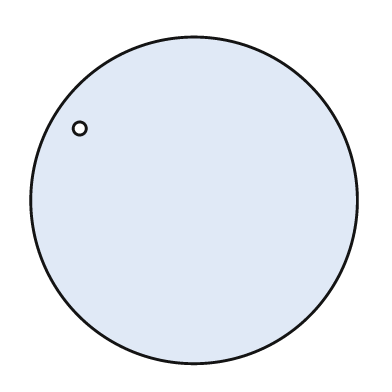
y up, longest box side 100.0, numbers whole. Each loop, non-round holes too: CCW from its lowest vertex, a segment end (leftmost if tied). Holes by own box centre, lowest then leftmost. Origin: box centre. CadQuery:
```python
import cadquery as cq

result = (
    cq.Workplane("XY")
    .moveTo(0.0, 0.0)
    .circle(50.0)
    .moveTo(-35.0, 22.0)
    .circle(2.0)
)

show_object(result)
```